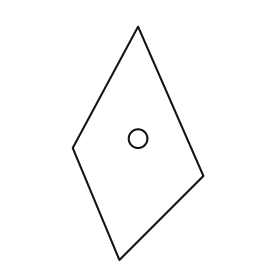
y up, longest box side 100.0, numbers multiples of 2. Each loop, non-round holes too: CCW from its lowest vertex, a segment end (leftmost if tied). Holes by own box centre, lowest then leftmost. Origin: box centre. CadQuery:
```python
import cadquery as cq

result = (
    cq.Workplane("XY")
    .moveTo(-8.0, -50.0)
    .lineTo(28.0, -14.0)
    .lineTo(0.0, 50.0)
    .lineTo(-28.0, -2.0)
    .close()
    .moveTo(0.0, 2.0)
    .circle(4.0)
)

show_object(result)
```